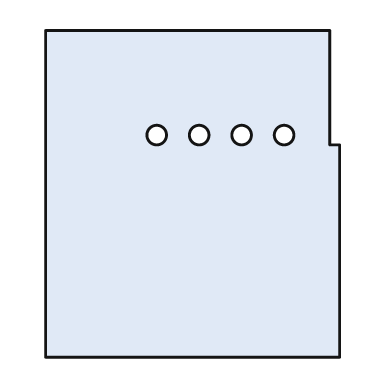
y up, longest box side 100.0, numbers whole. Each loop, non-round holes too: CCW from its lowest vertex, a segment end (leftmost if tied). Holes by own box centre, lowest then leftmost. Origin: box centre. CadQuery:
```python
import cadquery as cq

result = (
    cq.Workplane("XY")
    .moveTo(-45.0, -50.0)
    .lineTo(45.0, -50.0)
    .lineTo(45.0, 15.0)
    .lineTo(42.0, 15.0)
    .lineTo(42.0, 50.0)
    .lineTo(-45.0, 50.0)
    .close()
    .moveTo(-11.0, 18.0)
    .circle(3.0)
    .moveTo(2.0, 18.0)
    .circle(3.0)
    .moveTo(15.0, 18.0)
    .circle(3.0)
    .moveTo(28.0, 18.0)
    .circle(3.0)
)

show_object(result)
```